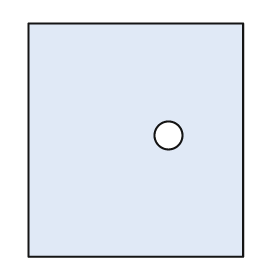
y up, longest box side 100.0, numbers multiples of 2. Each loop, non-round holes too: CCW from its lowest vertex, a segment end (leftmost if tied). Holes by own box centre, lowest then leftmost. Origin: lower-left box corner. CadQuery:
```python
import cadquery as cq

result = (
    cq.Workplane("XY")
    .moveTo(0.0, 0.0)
    .lineTo(92.0, 0.0)
    .lineTo(92.0, 100.0)
    .lineTo(0.0, 100.0)
    .close()
    .moveTo(60.0, 52.0)
    .circle(6.0)
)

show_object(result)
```